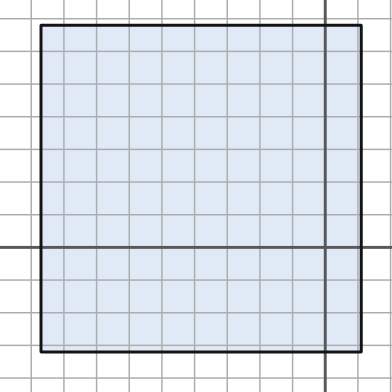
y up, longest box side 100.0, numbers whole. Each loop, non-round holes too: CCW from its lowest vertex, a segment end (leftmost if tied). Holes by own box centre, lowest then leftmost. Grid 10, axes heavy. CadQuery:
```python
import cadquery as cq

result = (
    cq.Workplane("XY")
    .moveTo(-87.0, -32.0)
    .lineTo(11.0, -32.0)
    .lineTo(11.0, 68.0)
    .lineTo(-87.0, 68.0)
    .close()
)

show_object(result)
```